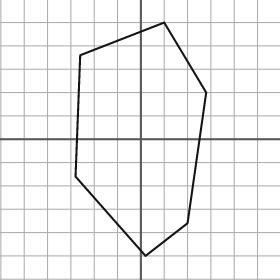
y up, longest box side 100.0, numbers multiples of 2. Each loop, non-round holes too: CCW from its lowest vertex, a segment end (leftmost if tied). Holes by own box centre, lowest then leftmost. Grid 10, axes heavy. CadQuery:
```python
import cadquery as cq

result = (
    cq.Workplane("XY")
    .moveTo(2.0, -50.0)
    .lineTo(20.0, -36.0)
    .lineTo(28.0, 20.0)
    .lineTo(10.0, 50.0)
    .lineTo(-26.0, 36.0)
    .lineTo(-28.0, -16.0)
    .close()
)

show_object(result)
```